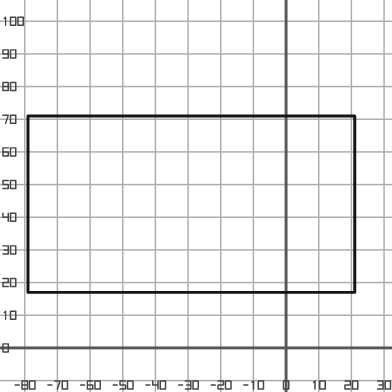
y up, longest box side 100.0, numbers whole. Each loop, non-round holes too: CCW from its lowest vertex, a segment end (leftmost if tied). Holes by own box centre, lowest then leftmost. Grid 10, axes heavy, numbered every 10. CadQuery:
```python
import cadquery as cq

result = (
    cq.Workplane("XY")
    .moveTo(-79.0, 17.0)
    .lineTo(21.0, 17.0)
    .lineTo(21.0, 71.0)
    .lineTo(-79.0, 71.0)
    .close()
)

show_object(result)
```